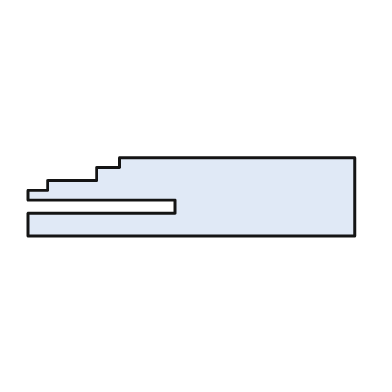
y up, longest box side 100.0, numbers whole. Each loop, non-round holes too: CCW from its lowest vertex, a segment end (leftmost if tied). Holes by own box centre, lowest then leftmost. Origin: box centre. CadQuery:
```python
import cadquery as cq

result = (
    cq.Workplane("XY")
    .moveTo(-50.0, -12.0)
    .lineTo(50.0, -12.0)
    .lineTo(50.0, 12.0)
    .lineTo(-22.0, 12.0)
    .lineTo(-22.0, 9.0)
    .lineTo(-29.0, 9.0)
    .lineTo(-29.0, 5.0)
    .lineTo(-44.0, 5.0)
    .lineTo(-44.0, 2.0)
    .lineTo(-50.0, 2.0)
    .lineTo(-50.0, -1.0)
    .lineTo(-5.0, -1.0)
    .lineTo(-5.0, -5.0)
    .lineTo(-50.0, -5.0)
    .close()
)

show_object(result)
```